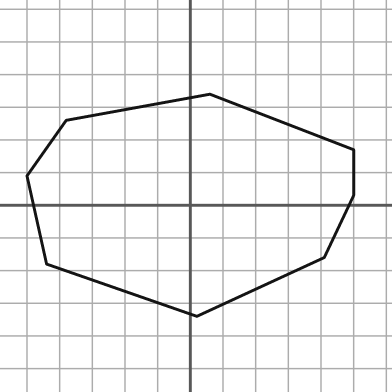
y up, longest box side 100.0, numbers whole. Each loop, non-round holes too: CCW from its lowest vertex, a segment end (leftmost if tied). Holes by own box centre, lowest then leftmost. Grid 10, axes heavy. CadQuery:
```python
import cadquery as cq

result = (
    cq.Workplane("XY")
    .moveTo(2.0, -34.0)
    .lineTo(41.0, -16.0)
    .lineTo(50.0, 3.0)
    .lineTo(50.0, 17.0)
    .lineTo(6.0, 34.0)
    .lineTo(-38.0, 26.0)
    .lineTo(-50.0, 9.0)
    .lineTo(-44.0, -18.0)
    .close()
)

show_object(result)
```